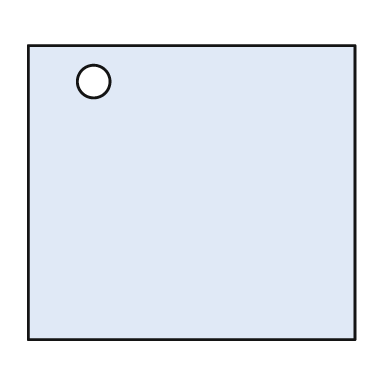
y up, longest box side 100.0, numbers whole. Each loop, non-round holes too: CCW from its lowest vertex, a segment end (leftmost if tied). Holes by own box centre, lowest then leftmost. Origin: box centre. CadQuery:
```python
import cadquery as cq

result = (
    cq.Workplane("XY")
    .moveTo(-50.0, -45.0)
    .lineTo(50.0, -45.0)
    .lineTo(50.0, 45.0)
    .lineTo(-50.0, 45.0)
    .close()
    .moveTo(-30.0, 34.0)
    .circle(5.0)
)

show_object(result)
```